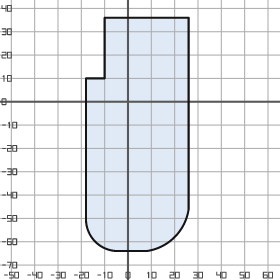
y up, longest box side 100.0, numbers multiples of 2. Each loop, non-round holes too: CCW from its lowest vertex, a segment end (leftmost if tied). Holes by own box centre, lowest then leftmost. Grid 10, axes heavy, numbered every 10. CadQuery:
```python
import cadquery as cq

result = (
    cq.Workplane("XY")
    .moveTo(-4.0, -64.0)
    .lineTo(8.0, -64.0)
    .threePointArc((20.0, -58.0), (26.0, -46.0))
    .lineTo(26.0, 36.0)
    .lineTo(-10.0, 36.0)
    .lineTo(-10.0, 10.0)
    .lineTo(-18.0, 10.0)
    .lineTo(-18.0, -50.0)
    .threePointArc((-14.0, -60.0), (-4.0, -64.0))
    .close()
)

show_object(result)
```